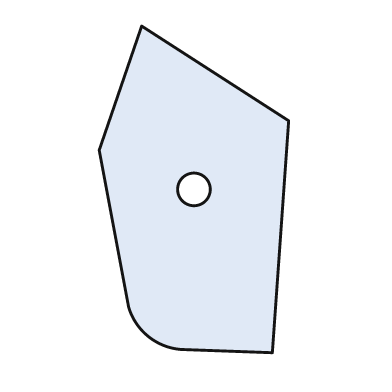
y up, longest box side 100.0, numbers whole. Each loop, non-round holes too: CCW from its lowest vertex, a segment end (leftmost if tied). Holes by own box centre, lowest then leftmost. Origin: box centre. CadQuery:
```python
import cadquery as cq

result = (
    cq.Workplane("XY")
    .moveTo(24.0, -50.0)
    .lineTo(29.0, 21.0)
    .lineTo(-16.0, 50.0)
    .lineTo(-29.0, 12.0)
    .lineTo(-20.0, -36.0)
    .threePointArc((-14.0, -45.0), (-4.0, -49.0))
    .close()
    .moveTo(0.0, 0.0)
    .circle(5.0)
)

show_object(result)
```